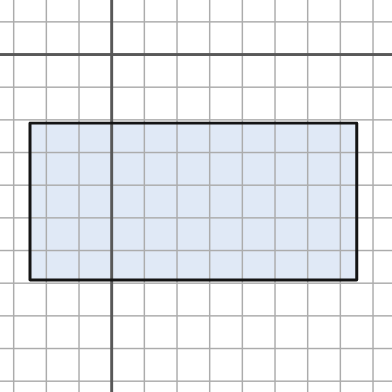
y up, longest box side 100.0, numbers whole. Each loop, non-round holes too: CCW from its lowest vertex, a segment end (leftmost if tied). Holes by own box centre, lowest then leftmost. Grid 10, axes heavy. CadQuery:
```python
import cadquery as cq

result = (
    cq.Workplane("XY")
    .moveTo(-25.0, -69.0)
    .lineTo(75.0, -69.0)
    .lineTo(75.0, -21.0)
    .lineTo(-25.0, -21.0)
    .close()
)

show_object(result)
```